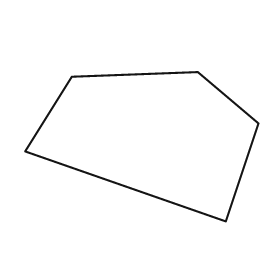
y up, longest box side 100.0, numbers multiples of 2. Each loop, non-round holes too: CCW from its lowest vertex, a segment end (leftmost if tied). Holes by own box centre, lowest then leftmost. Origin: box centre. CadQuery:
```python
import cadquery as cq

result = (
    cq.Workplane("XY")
    .moveTo(36.0, -32.0)
    .lineTo(50.0, 10.0)
    .lineTo(24.0, 32.0)
    .lineTo(-30.0, 30.0)
    .lineTo(-50.0, -2.0)
    .close()
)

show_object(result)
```